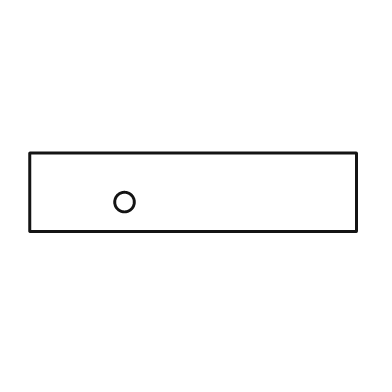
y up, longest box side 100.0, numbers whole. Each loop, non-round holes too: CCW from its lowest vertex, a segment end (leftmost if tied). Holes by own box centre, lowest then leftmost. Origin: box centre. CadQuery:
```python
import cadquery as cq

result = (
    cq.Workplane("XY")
    .moveTo(-50.0, -12.0)
    .lineTo(50.0, -12.0)
    .lineTo(50.0, 12.0)
    .lineTo(-50.0, 12.0)
    .close()
    .moveTo(-21.0, -3.0)
    .circle(3.0)
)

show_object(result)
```